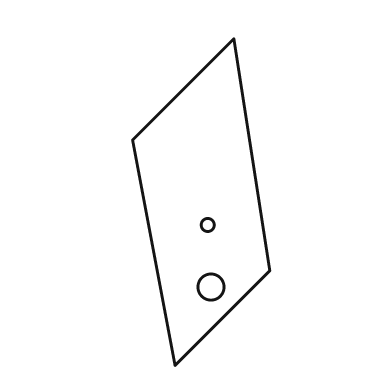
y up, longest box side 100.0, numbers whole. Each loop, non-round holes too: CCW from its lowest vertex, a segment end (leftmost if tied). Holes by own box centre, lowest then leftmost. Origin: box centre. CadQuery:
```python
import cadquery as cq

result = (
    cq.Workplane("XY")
    .moveTo(-8.0, -50.0)
    .lineTo(21.0, -21.0)
    .lineTo(10.0, 50.0)
    .lineTo(-21.0, 19.0)
    .close()
    .moveTo(3.0, -26.0)
    .circle(4.0)
    .moveTo(2.0, -7.0)
    .circle(2.0)
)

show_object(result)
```